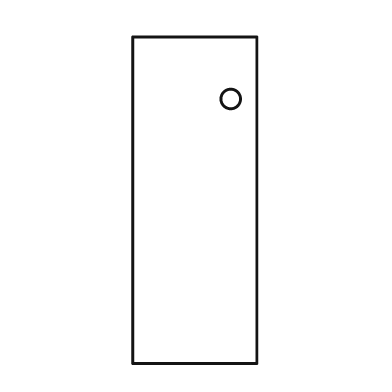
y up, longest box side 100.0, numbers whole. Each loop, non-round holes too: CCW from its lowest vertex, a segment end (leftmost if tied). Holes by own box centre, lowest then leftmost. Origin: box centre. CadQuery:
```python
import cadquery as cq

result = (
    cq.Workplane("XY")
    .moveTo(-19.0, -50.0)
    .lineTo(19.0, -50.0)
    .lineTo(19.0, 50.0)
    .lineTo(-19.0, 50.0)
    .close()
    .moveTo(11.0, 31.0)
    .circle(3.0)
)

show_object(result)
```